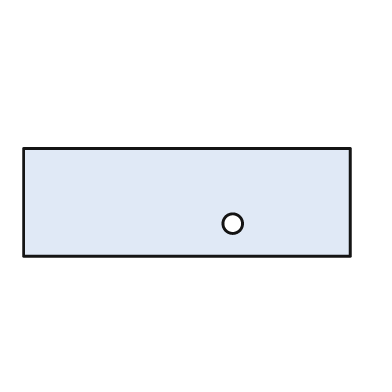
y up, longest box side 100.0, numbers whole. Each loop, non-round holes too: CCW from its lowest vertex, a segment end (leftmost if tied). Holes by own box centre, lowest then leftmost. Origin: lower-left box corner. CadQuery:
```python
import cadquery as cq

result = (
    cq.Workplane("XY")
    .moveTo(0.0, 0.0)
    .lineTo(100.0, 0.0)
    .lineTo(100.0, 33.0)
    .lineTo(0.0, 33.0)
    .close()
    .moveTo(64.0, 10.0)
    .circle(3.0)
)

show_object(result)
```